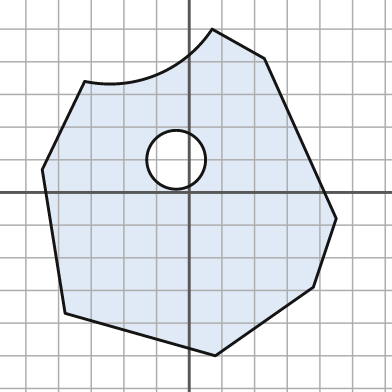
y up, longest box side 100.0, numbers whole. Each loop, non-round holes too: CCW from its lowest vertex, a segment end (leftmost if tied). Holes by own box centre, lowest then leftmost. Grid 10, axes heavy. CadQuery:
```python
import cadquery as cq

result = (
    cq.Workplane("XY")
    .moveTo(8.0, -50.0)
    .lineTo(38.0, -29.0)
    .lineTo(45.0, -8.0)
    .lineTo(23.0, 41.0)
    .lineTo(7.0, 50.0)
    .threePointArc((-10.0, 36.0), (-32.0, 34.0))
    .lineTo(-45.0, 7.0)
    .lineTo(-38.0, -37.0)
    .close()
    .moveTo(-4.0, 10.0)
    .circle(9.0)
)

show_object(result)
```